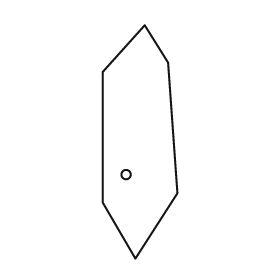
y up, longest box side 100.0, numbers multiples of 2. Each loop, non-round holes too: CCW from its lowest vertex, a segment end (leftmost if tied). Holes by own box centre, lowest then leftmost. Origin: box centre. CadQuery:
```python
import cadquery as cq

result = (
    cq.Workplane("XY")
    .moveTo(-2.0, -50.0)
    .lineTo(16.0, -22.0)
    .lineTo(12.0, 34.0)
    .lineTo(2.0, 50.0)
    .lineTo(-16.0, 30.0)
    .lineTo(-16.0, -26.0)
    .close()
    .moveTo(-6.0, -14.0)
    .circle(2.0)
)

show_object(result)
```